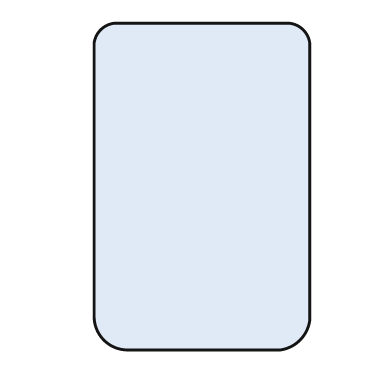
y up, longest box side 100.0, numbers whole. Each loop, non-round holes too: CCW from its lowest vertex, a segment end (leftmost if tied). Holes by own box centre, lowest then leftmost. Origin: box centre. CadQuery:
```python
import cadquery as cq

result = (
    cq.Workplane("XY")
    .moveTo(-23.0, -50.0)
    .lineTo(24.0, -50.0)
    .threePointArc((30.0, -47.0), (33.0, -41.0))
    .lineTo(33.0, 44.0)
    .threePointArc((31.0, 48.0), (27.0, 50.0))
    .lineTo(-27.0, 50.0)
    .threePointArc((-31.0, 48.0), (-33.0, 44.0))
    .lineTo(-33.0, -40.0)
    .threePointArc((-30.0, -47.0), (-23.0, -50.0))
    .close()
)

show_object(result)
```